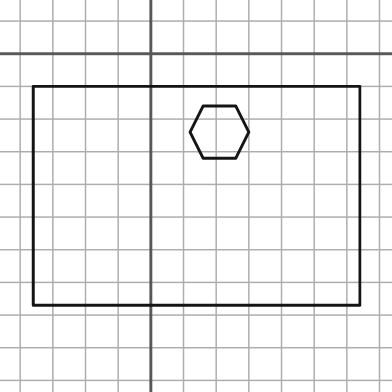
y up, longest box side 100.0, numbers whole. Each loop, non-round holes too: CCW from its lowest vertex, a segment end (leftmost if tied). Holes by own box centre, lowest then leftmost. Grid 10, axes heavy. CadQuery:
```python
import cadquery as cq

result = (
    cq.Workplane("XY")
    .moveTo(-36.0, -77.0)
    .lineTo(64.0, -77.0)
    .lineTo(64.0, -10.0)
    .lineTo(-36.0, -10.0)
    .close()
    .moveTo(16.0, -32.0)
    .lineTo(26.0, -32.0)
    .lineTo(30.0, -24.0)
    .lineTo(26.0, -16.0)
    .lineTo(16.0, -16.0)
    .lineTo(12.0, -24.0)
    .close()
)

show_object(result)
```